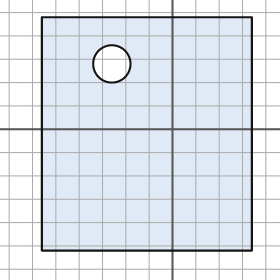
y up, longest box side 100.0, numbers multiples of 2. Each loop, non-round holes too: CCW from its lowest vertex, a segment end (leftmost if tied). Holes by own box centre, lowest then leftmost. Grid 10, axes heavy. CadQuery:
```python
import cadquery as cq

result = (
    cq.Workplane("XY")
    .moveTo(-56.0, -52.0)
    .lineTo(34.0, -52.0)
    .lineTo(34.0, 48.0)
    .lineTo(-56.0, 48.0)
    .close()
    .moveTo(-26.0, 28.0)
    .circle(8.0)
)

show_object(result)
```